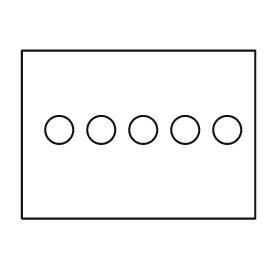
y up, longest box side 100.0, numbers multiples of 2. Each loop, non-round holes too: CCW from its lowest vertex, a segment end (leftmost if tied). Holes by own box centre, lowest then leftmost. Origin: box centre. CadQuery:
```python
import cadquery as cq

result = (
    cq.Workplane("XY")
    .moveTo(-50.0, -36.0)
    .lineTo(50.0, -36.0)
    .lineTo(50.0, 36.0)
    .lineTo(-50.0, 36.0)
    .close()
    .moveTo(-34.0, 2.0)
    .circle(6.0)
    .moveTo(-16.0, 2.0)
    .circle(6.0)
    .moveTo(2.0, 2.0)
    .circle(6.0)
    .moveTo(20.0, 2.0)
    .circle(6.0)
    .moveTo(38.0, 2.0)
    .circle(6.0)
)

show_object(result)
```